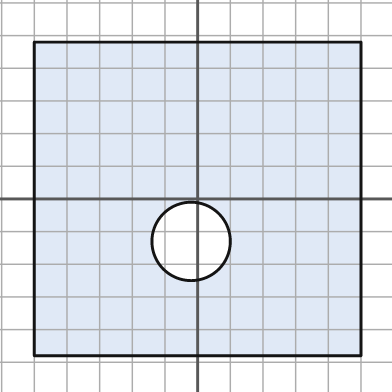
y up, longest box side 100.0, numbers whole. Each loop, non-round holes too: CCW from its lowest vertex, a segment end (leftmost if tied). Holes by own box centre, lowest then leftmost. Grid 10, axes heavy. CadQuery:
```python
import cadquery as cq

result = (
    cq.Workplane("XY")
    .moveTo(-50.0, -48.0)
    .lineTo(50.0, -48.0)
    .lineTo(50.0, 48.0)
    .lineTo(-50.0, 48.0)
    .close()
    .moveTo(-2.0, -13.0)
    .circle(12.0)
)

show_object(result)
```